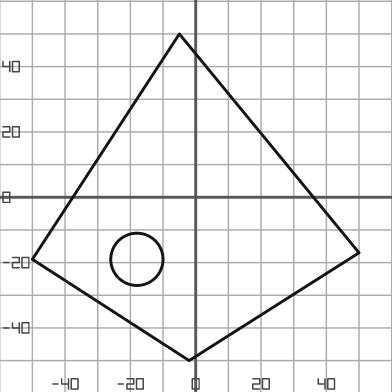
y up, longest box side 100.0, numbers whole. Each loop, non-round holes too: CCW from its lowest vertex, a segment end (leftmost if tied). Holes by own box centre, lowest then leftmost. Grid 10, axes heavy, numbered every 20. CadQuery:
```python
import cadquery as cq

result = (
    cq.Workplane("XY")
    .moveTo(-2.0, -50.0)
    .lineTo(50.0, -17.0)
    .lineTo(-5.0, 50.0)
    .lineTo(-50.0, -19.0)
    .close()
    .moveTo(-18.0, -19.0)
    .circle(8.0)
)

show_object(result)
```